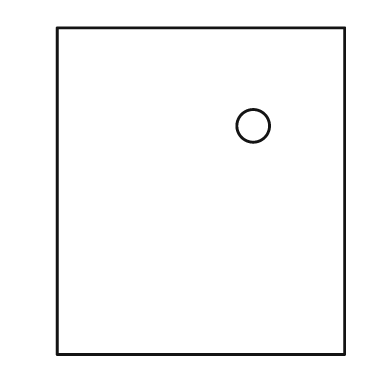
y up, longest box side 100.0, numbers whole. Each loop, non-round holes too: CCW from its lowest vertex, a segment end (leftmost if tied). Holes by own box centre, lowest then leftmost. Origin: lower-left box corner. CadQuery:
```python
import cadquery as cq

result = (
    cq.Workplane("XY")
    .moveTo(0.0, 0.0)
    .lineTo(88.0, 0.0)
    .lineTo(88.0, 100.0)
    .lineTo(0.0, 100.0)
    .close()
    .moveTo(60.0, 70.0)
    .circle(5.0)
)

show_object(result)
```